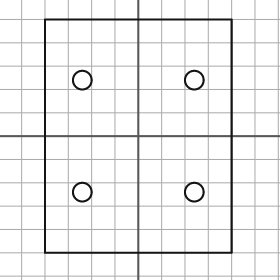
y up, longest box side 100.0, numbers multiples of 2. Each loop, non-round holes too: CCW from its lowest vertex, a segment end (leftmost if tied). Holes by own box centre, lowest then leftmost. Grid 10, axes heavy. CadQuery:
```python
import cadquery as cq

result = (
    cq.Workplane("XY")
    .moveTo(-40.0, -50.0)
    .lineTo(40.0, -50.0)
    .lineTo(40.0, 50.0)
    .lineTo(-40.0, 50.0)
    .close()
    .moveTo(-24.0, -24.0)
    .circle(4.0)
    .moveTo(24.0, -24.0)
    .circle(4.0)
    .moveTo(-24.0, 24.0)
    .circle(4.0)
    .moveTo(24.0, 24.0)
    .circle(4.0)
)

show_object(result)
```